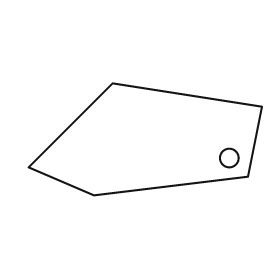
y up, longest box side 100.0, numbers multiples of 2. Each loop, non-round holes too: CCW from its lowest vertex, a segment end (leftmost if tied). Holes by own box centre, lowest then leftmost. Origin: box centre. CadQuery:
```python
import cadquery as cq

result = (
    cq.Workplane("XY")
    .moveTo(-22.0, -24.0)
    .lineTo(44.0, -16.0)
    .lineTo(50.0, 14.0)
    .lineTo(-14.0, 24.0)
    .lineTo(-50.0, -12.0)
    .close()
    .moveTo(36.0, -8.0)
    .circle(4.0)
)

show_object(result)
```